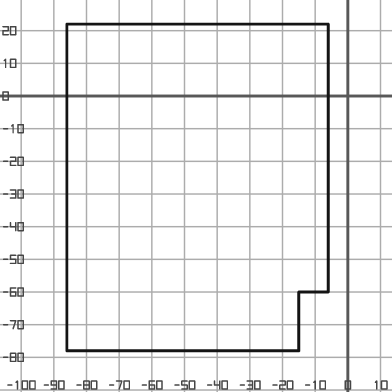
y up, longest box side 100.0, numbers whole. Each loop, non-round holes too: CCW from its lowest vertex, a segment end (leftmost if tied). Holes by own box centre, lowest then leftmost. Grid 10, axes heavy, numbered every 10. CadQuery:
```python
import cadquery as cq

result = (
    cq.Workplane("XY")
    .moveTo(-86.0, -78.0)
    .lineTo(-15.0, -78.0)
    .lineTo(-15.0, -60.0)
    .lineTo(-6.0, -60.0)
    .lineTo(-6.0, 22.0)
    .lineTo(-86.0, 22.0)
    .close()
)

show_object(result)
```